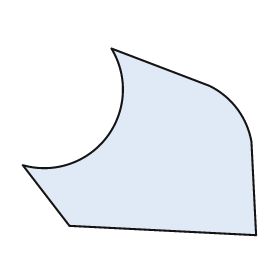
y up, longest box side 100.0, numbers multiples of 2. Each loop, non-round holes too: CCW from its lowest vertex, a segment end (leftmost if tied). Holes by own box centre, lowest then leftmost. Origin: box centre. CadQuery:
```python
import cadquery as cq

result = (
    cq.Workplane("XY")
    .moveTo(50.0, -40.0)
    .lineTo(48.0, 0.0)
    .threePointArc((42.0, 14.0), (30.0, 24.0))
    .lineTo(-12.0, 40.0)
    .threePointArc((-14.0, 2.0), (-50.0, -10.0))
    .lineTo(-30.0, -36.0)
    .close()
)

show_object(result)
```